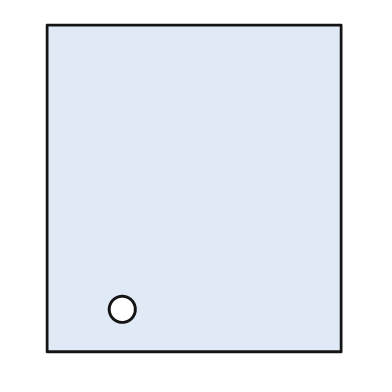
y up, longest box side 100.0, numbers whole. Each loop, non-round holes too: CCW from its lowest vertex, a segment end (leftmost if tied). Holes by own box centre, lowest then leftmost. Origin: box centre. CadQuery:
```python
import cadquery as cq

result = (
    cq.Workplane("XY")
    .moveTo(-45.0, -50.0)
    .lineTo(45.0, -50.0)
    .lineTo(45.0, 50.0)
    .lineTo(-45.0, 50.0)
    .close()
    .moveTo(-22.0, -37.0)
    .circle(4.0)
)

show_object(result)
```